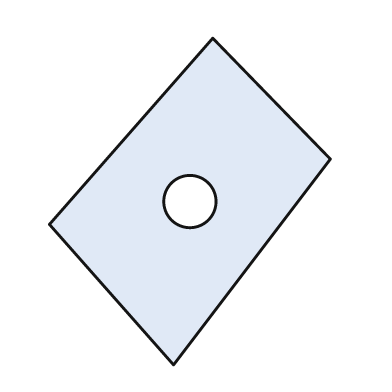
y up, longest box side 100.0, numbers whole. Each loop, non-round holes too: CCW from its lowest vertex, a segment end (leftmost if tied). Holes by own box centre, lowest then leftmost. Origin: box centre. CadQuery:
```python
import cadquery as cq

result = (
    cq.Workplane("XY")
    .moveTo(-5.0, -50.0)
    .lineTo(43.0, 13.0)
    .lineTo(7.0, 50.0)
    .lineTo(-43.0, -7.0)
    .close()
    .moveTo(0.0, 0.0)
    .circle(8.0)
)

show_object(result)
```